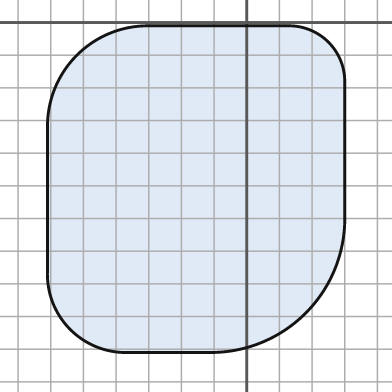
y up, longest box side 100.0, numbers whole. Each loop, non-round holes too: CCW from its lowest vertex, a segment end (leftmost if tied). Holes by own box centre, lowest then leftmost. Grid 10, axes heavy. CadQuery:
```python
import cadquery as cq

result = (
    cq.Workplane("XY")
    .moveTo(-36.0, -101.0)
    .lineTo(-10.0, -101.0)
    .threePointArc((18.0, -89.0), (30.0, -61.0))
    .lineTo(30.0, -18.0)
    .threePointArc((25.0, -6.0), (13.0, -1.0))
    .lineTo(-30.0, -1.0)
    .threePointArc((-52.0, -10.0), (-61.0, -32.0))
    .lineTo(-61.0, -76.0)
    .threePointArc((-54.0, -94.0), (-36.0, -101.0))
    .close()
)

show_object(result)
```